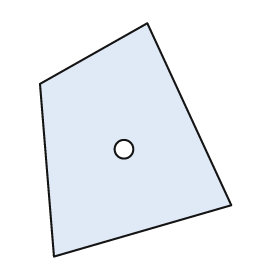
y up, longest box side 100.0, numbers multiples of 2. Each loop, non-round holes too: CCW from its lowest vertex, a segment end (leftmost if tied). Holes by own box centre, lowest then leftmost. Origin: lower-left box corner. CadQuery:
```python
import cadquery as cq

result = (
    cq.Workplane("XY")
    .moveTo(6.0, 0.0)
    .lineTo(82.0, 22.0)
    .lineTo(46.0, 100.0)
    .lineTo(0.0, 74.0)
    .close()
    .moveTo(36.0, 46.0)
    .circle(4.0)
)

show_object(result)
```